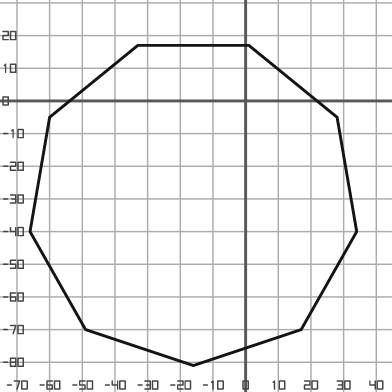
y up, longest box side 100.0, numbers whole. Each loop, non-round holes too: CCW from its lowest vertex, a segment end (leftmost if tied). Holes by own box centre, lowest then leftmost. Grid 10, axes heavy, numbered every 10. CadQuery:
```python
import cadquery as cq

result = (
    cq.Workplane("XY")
    .moveTo(-16.0, -81.0)
    .lineTo(17.0, -70.0)
    .lineTo(34.0, -40.0)
    .lineTo(28.0, -5.0)
    .lineTo(1.0, 17.0)
    .lineTo(-33.0, 17.0)
    .lineTo(-60.0, -5.0)
    .lineTo(-66.0, -40.0)
    .lineTo(-49.0, -70.0)
    .close()
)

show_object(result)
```